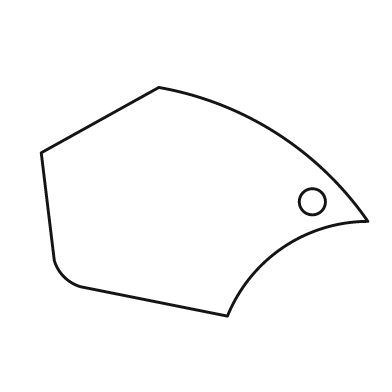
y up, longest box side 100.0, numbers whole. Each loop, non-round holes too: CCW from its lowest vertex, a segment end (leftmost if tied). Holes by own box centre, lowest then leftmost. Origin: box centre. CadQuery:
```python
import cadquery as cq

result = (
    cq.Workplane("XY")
    .moveTo(7.0, -35.0)
    .threePointArc((24.0, -14.0), (50.0, -6.0))
    .threePointArc((22.0, 21.0), (-14.0, 35.0))
    .lineTo(-50.0, 15.0)
    .lineTo(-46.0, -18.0)
    .threePointArc((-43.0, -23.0), (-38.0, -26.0))
    .close()
    .moveTo(33.0, 0.0)
    .circle(4.0)
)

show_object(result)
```